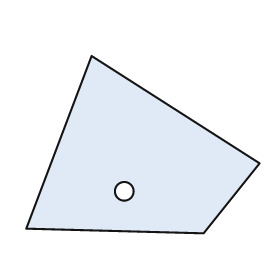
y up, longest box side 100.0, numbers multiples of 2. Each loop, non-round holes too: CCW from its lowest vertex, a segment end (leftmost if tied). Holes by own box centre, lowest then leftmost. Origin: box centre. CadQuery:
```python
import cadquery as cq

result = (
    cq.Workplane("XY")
    .moveTo(26.0, -38.0)
    .lineTo(50.0, -8.0)
    .lineTo(-22.0, 38.0)
    .lineTo(-50.0, -36.0)
    .close()
    .moveTo(-8.0, -20.0)
    .circle(4.0)
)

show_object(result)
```